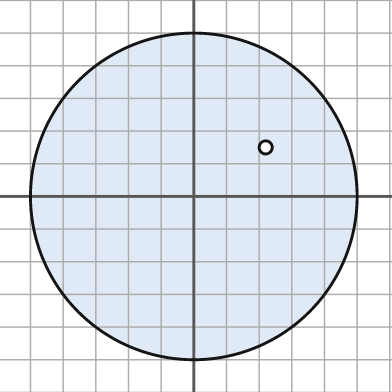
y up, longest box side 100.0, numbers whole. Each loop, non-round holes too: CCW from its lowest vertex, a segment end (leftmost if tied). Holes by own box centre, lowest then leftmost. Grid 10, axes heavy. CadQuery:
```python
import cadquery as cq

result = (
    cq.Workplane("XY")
    .moveTo(0.0, 0.0)
    .circle(50.0)
    .moveTo(22.0, 15.0)
    .circle(2.0)
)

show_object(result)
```